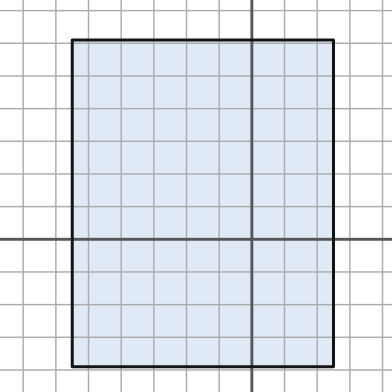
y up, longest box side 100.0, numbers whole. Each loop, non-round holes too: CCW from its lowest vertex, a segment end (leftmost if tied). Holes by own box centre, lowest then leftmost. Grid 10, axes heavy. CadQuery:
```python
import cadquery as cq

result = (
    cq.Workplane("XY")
    .moveTo(-55.0, -39.0)
    .lineTo(25.0, -39.0)
    .lineTo(25.0, 61.0)
    .lineTo(-55.0, 61.0)
    .close()
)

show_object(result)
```